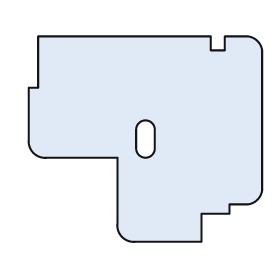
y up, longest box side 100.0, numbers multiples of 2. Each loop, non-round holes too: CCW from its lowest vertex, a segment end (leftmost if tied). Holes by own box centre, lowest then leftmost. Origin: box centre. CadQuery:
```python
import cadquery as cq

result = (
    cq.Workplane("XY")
    .moveTo(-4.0, -44.0)
    .lineTo(24.0, -44.0)
    .lineTo(24.0, -32.0)
    .lineTo(36.0, -32.0)
    .lineTo(36.0, -28.0)
    .lineTo(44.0, -28.0)
    .threePointArc((48.0, -26.0), (50.0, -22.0))
    .lineTo(50.0, 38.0)
    .threePointArc((48.0, 42.0), (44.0, 44.0))
    .lineTo(34.0, 44.0)
    .lineTo(34.0, 38.0)
    .lineTo(28.0, 38.0)
    .lineTo(28.0, 44.0)
    .lineTo(-46.0, 44.0)
    .lineTo(-46.0, 22.0)
    .lineTo(-50.0, 22.0)
    .lineTo(-50.0, 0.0)
    .threePointArc((-48.0, -6.0), (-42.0, -8.0))
    .lineTo(-12.0, -8.0)
    .lineTo(-12.0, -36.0)
    .threePointArc((-10.0, -42.0), (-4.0, -44.0))
    .close()
    .moveTo(-4.0, -4.0)
    .threePointArc((0.0, -8.0), (4.0, -4.0))
    .lineTo(4.0, 4.0)
    .threePointArc((0.0, 8.0), (-4.0, 4.0))
    .close()
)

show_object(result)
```